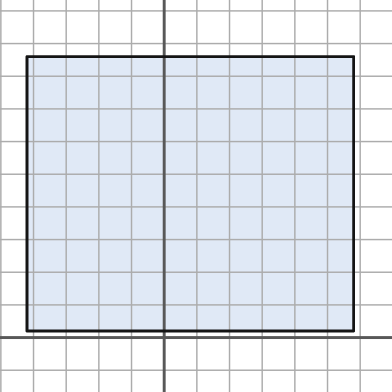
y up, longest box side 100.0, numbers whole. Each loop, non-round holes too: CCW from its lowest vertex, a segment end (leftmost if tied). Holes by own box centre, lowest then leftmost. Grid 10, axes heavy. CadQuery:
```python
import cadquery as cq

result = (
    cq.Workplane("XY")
    .moveTo(-42.0, 2.0)
    .lineTo(58.0, 2.0)
    .lineTo(58.0, 86.0)
    .lineTo(-42.0, 86.0)
    .close()
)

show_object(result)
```